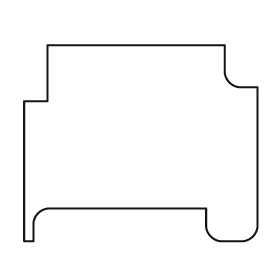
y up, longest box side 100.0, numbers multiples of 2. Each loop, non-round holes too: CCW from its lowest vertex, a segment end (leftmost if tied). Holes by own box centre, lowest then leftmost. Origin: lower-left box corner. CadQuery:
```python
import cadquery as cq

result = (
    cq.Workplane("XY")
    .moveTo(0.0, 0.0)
    .lineTo(4.0, 0.0)
    .lineTo(4.0, 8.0)
    .threePointArc((6.0, 12.0), (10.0, 14.0))
    .lineTo(78.0, 14.0)
    .lineTo(78.0, 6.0)
    .threePointArc((80.0, 2.0), (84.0, 0.0))
    .lineTo(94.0, 0.0)
    .threePointArc((98.0, 2.0), (100.0, 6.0))
    .lineTo(100.0, 66.0)
    .lineTo(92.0, 66.0)
    .threePointArc((88.0, 68.0), (86.0, 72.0))
    .lineTo(86.0, 84.0)
    .lineTo(10.0, 84.0)
    .lineTo(10.0, 60.0)
    .lineTo(0.0, 60.0)
    .close()
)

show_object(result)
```